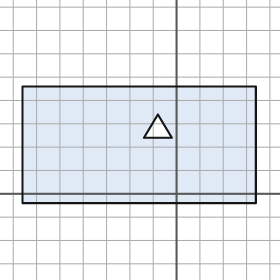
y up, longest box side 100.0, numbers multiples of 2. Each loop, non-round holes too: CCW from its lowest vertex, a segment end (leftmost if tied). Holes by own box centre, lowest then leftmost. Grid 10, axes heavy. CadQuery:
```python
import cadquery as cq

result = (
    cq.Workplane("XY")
    .moveTo(-66.0, -4.0)
    .lineTo(34.0, -4.0)
    .lineTo(34.0, 46.0)
    .lineTo(-66.0, 46.0)
    .close()
    .moveTo(-14.0, 24.0)
    .lineTo(-2.0, 24.0)
    .lineTo(-8.0, 34.0)
    .close()
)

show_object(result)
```